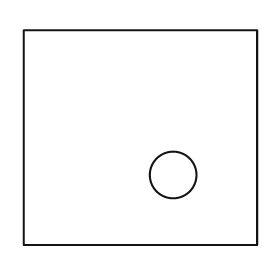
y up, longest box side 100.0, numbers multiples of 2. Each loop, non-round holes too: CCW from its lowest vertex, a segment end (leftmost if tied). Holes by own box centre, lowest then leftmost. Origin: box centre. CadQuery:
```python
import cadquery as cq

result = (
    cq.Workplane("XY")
    .moveTo(-50.0, -46.0)
    .lineTo(50.0, -46.0)
    .lineTo(50.0, 46.0)
    .lineTo(-50.0, 46.0)
    .close()
    .moveTo(14.0, -16.0)
    .circle(10.0)
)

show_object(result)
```